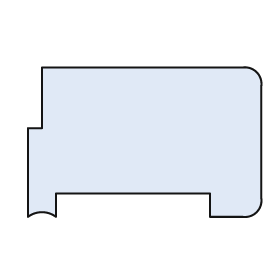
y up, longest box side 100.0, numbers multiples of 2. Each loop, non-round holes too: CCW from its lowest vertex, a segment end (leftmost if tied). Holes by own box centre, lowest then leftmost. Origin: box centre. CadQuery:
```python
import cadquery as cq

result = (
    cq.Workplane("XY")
    .moveTo(-50.0, -32.0)
    .threePointArc((-44.0, -30.0), (-38.0, -32.0))
    .lineTo(-38.0, -22.0)
    .lineTo(28.0, -22.0)
    .lineTo(28.0, -32.0)
    .lineTo(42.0, -32.0)
    .threePointArc((48.0, -30.0), (50.0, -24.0))
    .lineTo(50.0, 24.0)
    .threePointArc((48.0, 30.0), (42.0, 32.0))
    .lineTo(-44.0, 32.0)
    .lineTo(-44.0, 6.0)
    .lineTo(-50.0, 6.0)
    .close()
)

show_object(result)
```